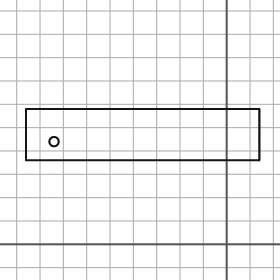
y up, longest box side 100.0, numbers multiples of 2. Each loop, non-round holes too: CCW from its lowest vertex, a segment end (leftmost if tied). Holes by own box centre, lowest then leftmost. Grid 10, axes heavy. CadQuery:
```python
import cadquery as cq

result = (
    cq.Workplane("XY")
    .moveTo(-86.0, 36.0)
    .lineTo(14.0, 36.0)
    .lineTo(14.0, 58.0)
    .lineTo(-86.0, 58.0)
    .close()
    .moveTo(-74.0, 44.0)
    .circle(2.0)
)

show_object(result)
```